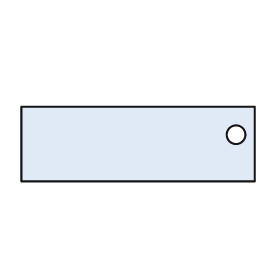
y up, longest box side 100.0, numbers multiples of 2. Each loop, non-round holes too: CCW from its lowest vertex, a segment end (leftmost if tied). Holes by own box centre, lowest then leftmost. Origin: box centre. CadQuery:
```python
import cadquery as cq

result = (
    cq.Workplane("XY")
    .moveTo(-50.0, -16.0)
    .lineTo(50.0, -16.0)
    .lineTo(50.0, 16.0)
    .lineTo(-50.0, 16.0)
    .close()
    .moveTo(42.0, 4.0)
    .circle(4.0)
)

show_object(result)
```